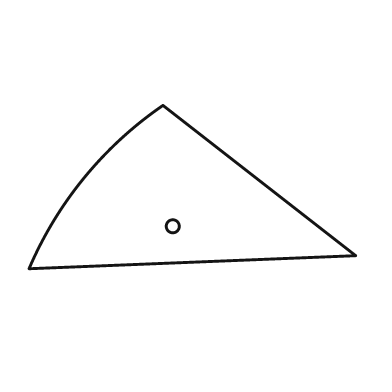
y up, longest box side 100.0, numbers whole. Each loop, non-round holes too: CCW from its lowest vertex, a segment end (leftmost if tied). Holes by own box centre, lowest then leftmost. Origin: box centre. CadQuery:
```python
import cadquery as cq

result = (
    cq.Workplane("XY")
    .moveTo(-50.0, -25.0)
    .lineTo(50.0, -21.0)
    .lineTo(-9.0, 25.0)
    .threePointArc((-33.0, 3.0), (-50.0, -25.0))
    .close()
    .moveTo(-6.0, -12.0)
    .circle(2.0)
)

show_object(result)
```